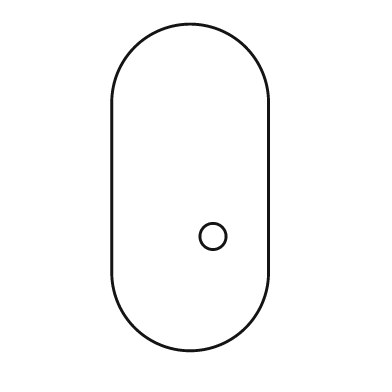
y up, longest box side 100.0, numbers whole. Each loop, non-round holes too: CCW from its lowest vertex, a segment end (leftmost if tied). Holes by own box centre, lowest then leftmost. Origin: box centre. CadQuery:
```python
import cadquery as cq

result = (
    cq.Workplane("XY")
    .moveTo(-24.0, -26.0)
    .threePointArc((0.0, -50.0), (24.0, -26.0))
    .lineTo(24.0, 26.0)
    .threePointArc((0.0, 50.0), (-24.0, 26.0))
    .close()
    .moveTo(7.0, -15.0)
    .circle(4.0)
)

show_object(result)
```